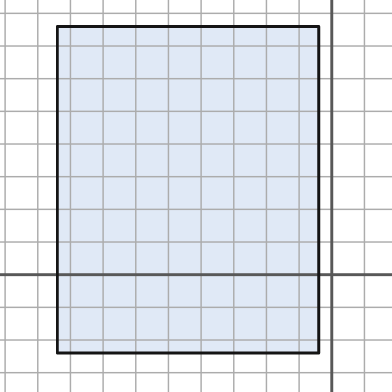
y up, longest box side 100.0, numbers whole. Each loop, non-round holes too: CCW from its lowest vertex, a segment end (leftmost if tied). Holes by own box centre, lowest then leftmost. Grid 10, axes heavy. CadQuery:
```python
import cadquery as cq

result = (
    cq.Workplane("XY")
    .moveTo(-84.0, -24.0)
    .lineTo(-4.0, -24.0)
    .lineTo(-4.0, 76.0)
    .lineTo(-84.0, 76.0)
    .close()
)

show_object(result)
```